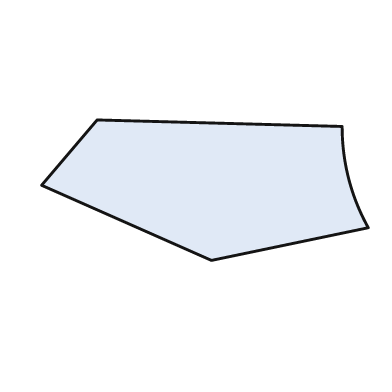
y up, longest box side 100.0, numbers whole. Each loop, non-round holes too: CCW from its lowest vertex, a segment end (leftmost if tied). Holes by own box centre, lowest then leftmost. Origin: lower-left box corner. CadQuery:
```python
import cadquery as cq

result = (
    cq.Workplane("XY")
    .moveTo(52.0, 0.0)
    .lineTo(100.0, 10.0)
    .threePointArc((94.0, 25.0), (92.0, 41.0))
    .lineTo(17.0, 43.0)
    .lineTo(0.0, 23.0)
    .close()
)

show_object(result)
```